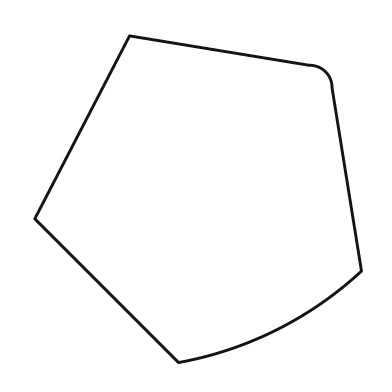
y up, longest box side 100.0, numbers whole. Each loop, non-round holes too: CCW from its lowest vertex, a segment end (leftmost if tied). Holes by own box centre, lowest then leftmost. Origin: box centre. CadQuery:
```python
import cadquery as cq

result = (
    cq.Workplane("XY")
    .moveTo(-6.0, -50.0)
    .threePointArc((24.0, -40.0), (50.0, -22.0))
    .lineTo(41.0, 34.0)
    .threePointArc((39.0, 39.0), (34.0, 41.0))
    .lineTo(-21.0, 50.0)
    .lineTo(-50.0, -6.0)
    .close()
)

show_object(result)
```